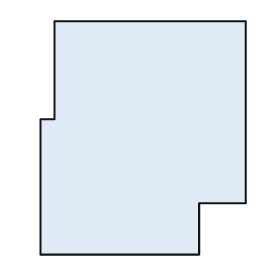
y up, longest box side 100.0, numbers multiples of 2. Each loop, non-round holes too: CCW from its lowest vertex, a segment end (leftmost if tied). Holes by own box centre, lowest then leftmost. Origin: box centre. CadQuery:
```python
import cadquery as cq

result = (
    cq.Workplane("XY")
    .moveTo(-44.0, -50.0)
    .lineTo(24.0, -50.0)
    .lineTo(24.0, -28.0)
    .lineTo(44.0, -28.0)
    .lineTo(44.0, 50.0)
    .lineTo(-38.0, 50.0)
    .lineTo(-38.0, 8.0)
    .lineTo(-44.0, 8.0)
    .close()
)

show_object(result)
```